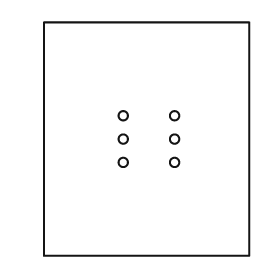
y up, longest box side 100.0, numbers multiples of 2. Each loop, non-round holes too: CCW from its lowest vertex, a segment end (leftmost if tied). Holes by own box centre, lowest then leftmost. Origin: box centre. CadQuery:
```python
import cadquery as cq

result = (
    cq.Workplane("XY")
    .moveTo(-44.0, -50.0)
    .lineTo(44.0, -50.0)
    .lineTo(44.0, 50.0)
    .lineTo(-44.0, 50.0)
    .close()
    .moveTo(-10.0, -10.0)
    .circle(2.0)
    .moveTo(12.0, -10.0)
    .circle(2.0)
    .moveTo(-10.0, 0.0)
    .circle(2.0)
    .moveTo(12.0, 0.0)
    .circle(2.0)
    .moveTo(-10.0, 10.0)
    .circle(2.0)
    .moveTo(12.0, 10.0)
    .circle(2.0)
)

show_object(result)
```